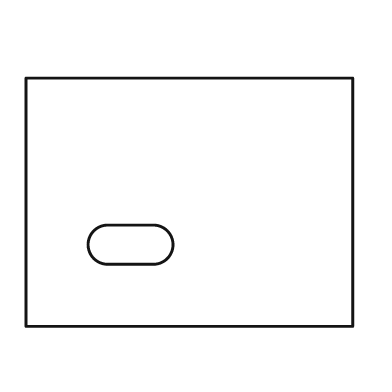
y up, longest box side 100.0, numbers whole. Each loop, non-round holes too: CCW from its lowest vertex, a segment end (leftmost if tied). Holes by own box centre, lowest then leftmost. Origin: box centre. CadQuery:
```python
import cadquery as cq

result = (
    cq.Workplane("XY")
    .moveTo(-50.0, -38.0)
    .lineTo(50.0, -38.0)
    .lineTo(50.0, 38.0)
    .lineTo(-50.0, 38.0)
    .close()
    .moveTo(-25.0, -19.0)
    .lineTo(-11.0, -19.0)
    .threePointArc((-5.0, -13.0), (-11.0, -7.0))
    .lineTo(-25.0, -7.0)
    .threePointArc((-31.0, -13.0), (-25.0, -19.0))
    .close()
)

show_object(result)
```